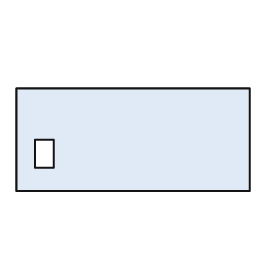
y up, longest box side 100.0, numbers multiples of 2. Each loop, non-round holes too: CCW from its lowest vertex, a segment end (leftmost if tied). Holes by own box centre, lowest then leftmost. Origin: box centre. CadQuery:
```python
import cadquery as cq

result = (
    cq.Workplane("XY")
    .moveTo(-50.0, -22.0)
    .lineTo(50.0, -22.0)
    .lineTo(50.0, 22.0)
    .lineTo(-50.0, 22.0)
    .close()
    .moveTo(-42.0, -12.0)
    .lineTo(-34.0, -12.0)
    .lineTo(-34.0, 0.0)
    .lineTo(-42.0, 0.0)
    .close()
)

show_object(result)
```